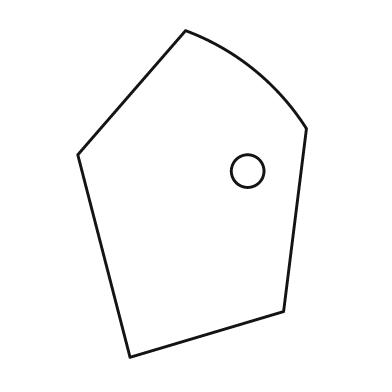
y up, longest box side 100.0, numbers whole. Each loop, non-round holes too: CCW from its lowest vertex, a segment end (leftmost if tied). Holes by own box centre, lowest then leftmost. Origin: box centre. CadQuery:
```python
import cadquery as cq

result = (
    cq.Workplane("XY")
    .moveTo(-19.0, -50.0)
    .lineTo(28.0, -36.0)
    .lineTo(35.0, 20.0)
    .threePointArc((19.0, 38.0), (-2.0, 50.0))
    .lineTo(-35.0, 12.0)
    .close()
    .moveTo(17.0, 7.0)
    .circle(5.0)
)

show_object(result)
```